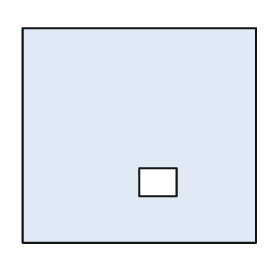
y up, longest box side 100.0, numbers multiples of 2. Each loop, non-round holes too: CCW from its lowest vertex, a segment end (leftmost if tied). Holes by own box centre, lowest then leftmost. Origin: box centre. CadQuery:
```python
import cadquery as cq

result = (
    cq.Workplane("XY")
    .moveTo(-50.0, -46.0)
    .lineTo(50.0, -46.0)
    .lineTo(50.0, 46.0)
    .lineTo(-50.0, 46.0)
    .close()
    .moveTo(0.0, -26.0)
    .lineTo(16.0, -26.0)
    .lineTo(16.0, -14.0)
    .lineTo(0.0, -14.0)
    .close()
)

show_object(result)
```